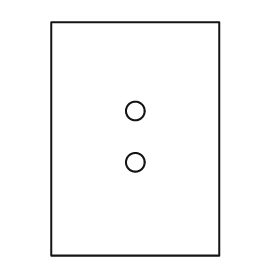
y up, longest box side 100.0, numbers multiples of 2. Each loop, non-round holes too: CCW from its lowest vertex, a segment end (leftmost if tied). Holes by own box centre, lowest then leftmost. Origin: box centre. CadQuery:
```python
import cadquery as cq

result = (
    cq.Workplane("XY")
    .moveTo(-36.0, -50.0)
    .lineTo(36.0, -50.0)
    .lineTo(36.0, 50.0)
    .lineTo(-36.0, 50.0)
    .close()
    .moveTo(0.0, -10.0)
    .circle(4.0)
    .moveTo(0.0, 12.0)
    .circle(4.0)
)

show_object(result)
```